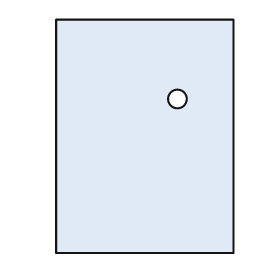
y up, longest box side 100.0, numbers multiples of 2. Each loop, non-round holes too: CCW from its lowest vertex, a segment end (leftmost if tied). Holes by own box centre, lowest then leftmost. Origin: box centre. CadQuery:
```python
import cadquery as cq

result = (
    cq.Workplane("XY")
    .moveTo(-38.0, -50.0)
    .lineTo(38.0, -50.0)
    .lineTo(38.0, 50.0)
    .lineTo(-38.0, 50.0)
    .close()
    .moveTo(14.0, 16.0)
    .circle(4.0)
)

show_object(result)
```